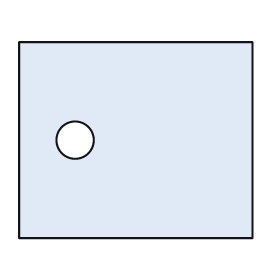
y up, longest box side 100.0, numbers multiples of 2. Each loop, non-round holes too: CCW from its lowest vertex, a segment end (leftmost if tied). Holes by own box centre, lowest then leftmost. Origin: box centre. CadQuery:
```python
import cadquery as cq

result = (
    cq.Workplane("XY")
    .moveTo(-50.0, -42.0)
    .lineTo(50.0, -42.0)
    .lineTo(50.0, 42.0)
    .lineTo(-50.0, 42.0)
    .close()
    .moveTo(-26.0, 0.0)
    .circle(8.0)
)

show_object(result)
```